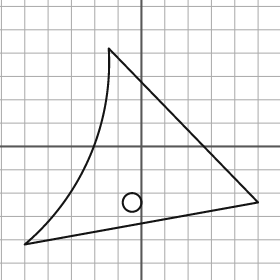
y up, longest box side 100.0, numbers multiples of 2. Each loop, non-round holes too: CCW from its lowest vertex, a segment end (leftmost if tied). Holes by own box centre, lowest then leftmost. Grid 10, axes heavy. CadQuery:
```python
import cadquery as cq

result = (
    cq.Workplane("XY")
    .moveTo(-50.0, -42.0)
    .lineTo(50.0, -24.0)
    .lineTo(-14.0, 42.0)
    .threePointArc((-22.0, -4.0), (-50.0, -42.0))
    .close()
    .moveTo(-4.0, -24.0)
    .circle(4.0)
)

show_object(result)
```